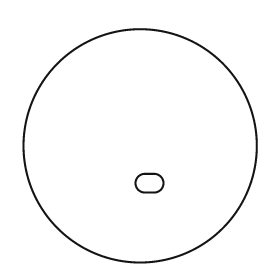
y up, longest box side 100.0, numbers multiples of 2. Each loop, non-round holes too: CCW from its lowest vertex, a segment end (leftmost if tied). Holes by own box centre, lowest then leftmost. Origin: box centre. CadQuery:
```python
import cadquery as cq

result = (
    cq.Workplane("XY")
    .moveTo(0.0, 0.0)
    .circle(50.0)
    .moveTo(2.0, -20.0)
    .lineTo(6.0, -20.0)
    .threePointArc((10.0, -16.0), (6.0, -12.0))
    .lineTo(2.0, -12.0)
    .threePointArc((-2.0, -16.0), (2.0, -20.0))
    .close()
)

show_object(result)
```